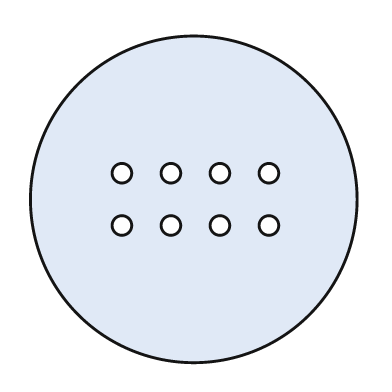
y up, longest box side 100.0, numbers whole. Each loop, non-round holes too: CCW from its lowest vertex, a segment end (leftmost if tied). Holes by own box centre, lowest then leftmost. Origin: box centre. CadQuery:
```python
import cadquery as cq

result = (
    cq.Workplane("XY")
    .moveTo(0.0, 0.0)
    .circle(50.0)
    .moveTo(-22.0, -8.0)
    .circle(3.0)
    .moveTo(-7.0, -8.0)
    .circle(3.0)
    .moveTo(8.0, -8.0)
    .circle(3.0)
    .moveTo(23.0, -8.0)
    .circle(3.0)
    .moveTo(-22.0, 8.0)
    .circle(3.0)
    .moveTo(-7.0, 8.0)
    .circle(3.0)
    .moveTo(8.0, 8.0)
    .circle(3.0)
    .moveTo(23.0, 8.0)
    .circle(3.0)
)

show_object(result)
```